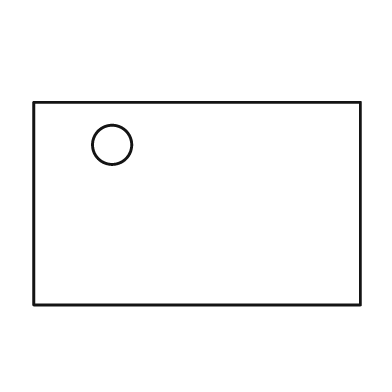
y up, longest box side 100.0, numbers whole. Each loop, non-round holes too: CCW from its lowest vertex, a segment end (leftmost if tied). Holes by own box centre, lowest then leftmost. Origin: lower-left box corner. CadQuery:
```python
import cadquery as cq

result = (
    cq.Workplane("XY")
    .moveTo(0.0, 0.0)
    .lineTo(100.0, 0.0)
    .lineTo(100.0, 62.0)
    .lineTo(0.0, 62.0)
    .close()
    .moveTo(24.0, 49.0)
    .circle(6.0)
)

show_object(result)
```